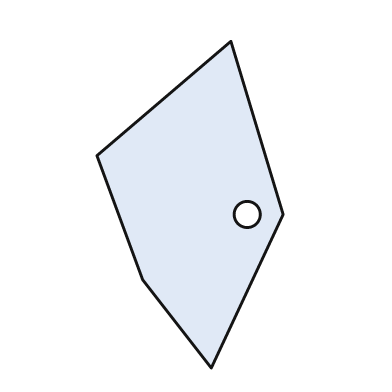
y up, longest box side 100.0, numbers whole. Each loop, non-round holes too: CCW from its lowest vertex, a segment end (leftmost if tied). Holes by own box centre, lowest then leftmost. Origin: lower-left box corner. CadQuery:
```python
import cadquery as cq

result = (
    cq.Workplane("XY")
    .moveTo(35.0, 0.0)
    .lineTo(57.0, 47.0)
    .lineTo(41.0, 100.0)
    .lineTo(0.0, 65.0)
    .lineTo(14.0, 27.0)
    .close()
    .moveTo(46.0, 47.0)
    .circle(4.0)
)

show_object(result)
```